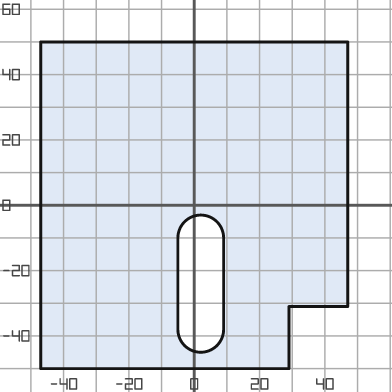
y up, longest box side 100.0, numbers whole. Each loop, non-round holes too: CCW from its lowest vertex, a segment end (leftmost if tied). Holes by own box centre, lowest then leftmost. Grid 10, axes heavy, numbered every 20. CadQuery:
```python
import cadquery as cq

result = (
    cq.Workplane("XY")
    .moveTo(-47.0, -50.0)
    .lineTo(29.0, -50.0)
    .lineTo(29.0, -31.0)
    .lineTo(47.0, -31.0)
    .lineTo(47.0, 50.0)
    .lineTo(-47.0, 50.0)
    .close()
    .moveTo(-5.0, -38.0)
    .threePointArc((2.0, -45.0), (9.0, -38.0))
    .lineTo(9.0, -10.0)
    .threePointArc((2.0, -3.0), (-5.0, -10.0))
    .close()
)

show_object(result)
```